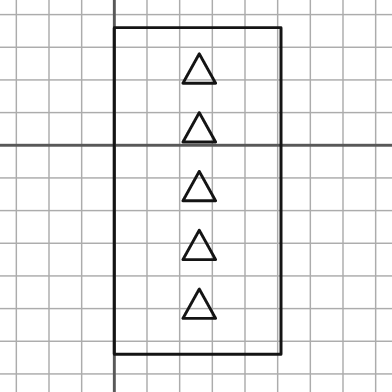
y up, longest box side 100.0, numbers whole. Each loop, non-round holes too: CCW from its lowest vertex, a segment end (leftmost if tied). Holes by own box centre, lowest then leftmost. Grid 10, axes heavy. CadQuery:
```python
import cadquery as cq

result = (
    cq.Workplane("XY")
    .moveTo(0.0, -64.0)
    .lineTo(51.0, -64.0)
    .lineTo(51.0, 36.0)
    .lineTo(0.0, 36.0)
    .close()
    .moveTo(21.0, -53.0)
    .lineTo(31.0, -53.0)
    .lineTo(26.0, -44.0)
    .close()
    .moveTo(21.0, -35.0)
    .lineTo(31.0, -35.0)
    .lineTo(26.0, -26.0)
    .close()
    .moveTo(21.0, -17.0)
    .lineTo(31.0, -17.0)
    .lineTo(26.0, -8.0)
    .close()
    .moveTo(21.0, 1.0)
    .lineTo(31.0, 1.0)
    .lineTo(26.0, 10.0)
    .close()
    .moveTo(21.0, 19.0)
    .lineTo(31.0, 19.0)
    .lineTo(26.0, 28.0)
    .close()
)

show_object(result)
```